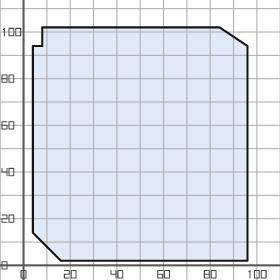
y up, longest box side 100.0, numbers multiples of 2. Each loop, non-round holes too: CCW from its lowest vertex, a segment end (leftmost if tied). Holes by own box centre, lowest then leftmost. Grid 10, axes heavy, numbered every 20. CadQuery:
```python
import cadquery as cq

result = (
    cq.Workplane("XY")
    .moveTo(16.0, 2.0)
    .lineTo(96.0, 2.0)
    .lineTo(96.0, 94.0)
    .lineTo(84.0, 102.0)
    .lineTo(8.0, 102.0)
    .lineTo(8.0, 94.0)
    .lineTo(4.0, 94.0)
    .lineTo(4.0, 14.0)
    .close()
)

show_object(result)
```